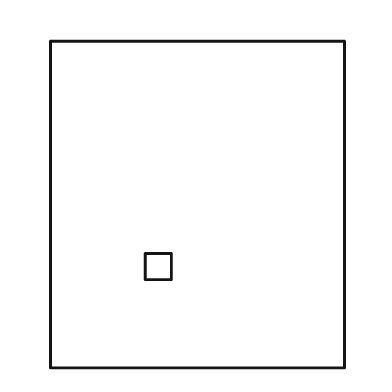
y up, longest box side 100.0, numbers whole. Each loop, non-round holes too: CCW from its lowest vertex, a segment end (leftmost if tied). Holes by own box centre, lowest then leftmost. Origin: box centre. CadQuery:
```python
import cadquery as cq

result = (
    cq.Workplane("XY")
    .moveTo(-45.0, -50.0)
    .lineTo(45.0, -50.0)
    .lineTo(45.0, 50.0)
    .lineTo(-45.0, 50.0)
    .close()
    .moveTo(-16.0, -23.0)
    .lineTo(-8.0, -23.0)
    .lineTo(-8.0, -15.0)
    .lineTo(-16.0, -15.0)
    .close()
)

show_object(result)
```